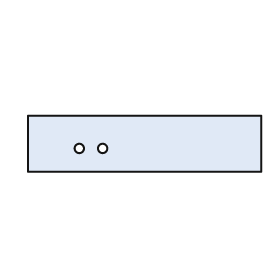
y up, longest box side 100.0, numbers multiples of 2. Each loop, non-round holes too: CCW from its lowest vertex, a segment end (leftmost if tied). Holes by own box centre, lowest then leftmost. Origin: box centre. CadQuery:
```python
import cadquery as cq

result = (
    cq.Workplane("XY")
    .moveTo(-50.0, -12.0)
    .lineTo(50.0, -12.0)
    .lineTo(50.0, 12.0)
    .lineTo(-50.0, 12.0)
    .close()
    .moveTo(-28.0, -2.0)
    .circle(2.0)
    .moveTo(-18.0, -2.0)
    .circle(2.0)
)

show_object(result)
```